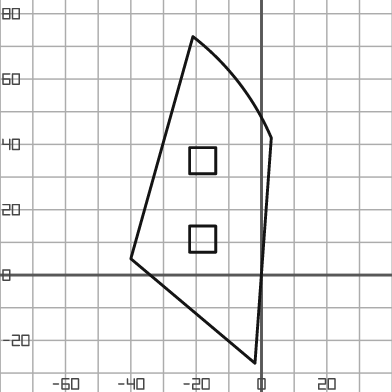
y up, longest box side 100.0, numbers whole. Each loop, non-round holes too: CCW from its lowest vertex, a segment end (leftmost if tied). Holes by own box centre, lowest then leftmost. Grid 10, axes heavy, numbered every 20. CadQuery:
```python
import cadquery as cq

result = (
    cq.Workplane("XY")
    .moveTo(-2.0, -27.0)
    .lineTo(3.0, 42.0)
    .threePointArc((-7.0, 59.0), (-21.0, 73.0))
    .lineTo(-40.0, 5.0)
    .close()
    .moveTo(-22.0, 7.0)
    .lineTo(-14.0, 7.0)
    .lineTo(-14.0, 15.0)
    .lineTo(-22.0, 15.0)
    .close()
    .moveTo(-22.0, 31.0)
    .lineTo(-14.0, 31.0)
    .lineTo(-14.0, 39.0)
    .lineTo(-22.0, 39.0)
    .close()
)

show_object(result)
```